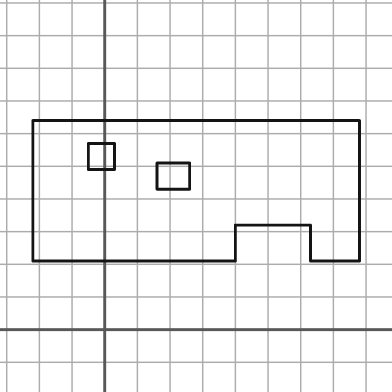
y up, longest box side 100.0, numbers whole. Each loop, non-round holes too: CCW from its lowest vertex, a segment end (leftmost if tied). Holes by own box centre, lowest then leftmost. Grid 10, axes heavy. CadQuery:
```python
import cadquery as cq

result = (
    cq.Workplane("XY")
    .moveTo(-22.0, 21.0)
    .lineTo(40.0, 21.0)
    .lineTo(40.0, 32.0)
    .lineTo(63.0, 32.0)
    .lineTo(63.0, 21.0)
    .lineTo(78.0, 21.0)
    .lineTo(78.0, 64.0)
    .lineTo(-22.0, 64.0)
    .close()
    .moveTo(16.0, 43.0)
    .lineTo(26.0, 43.0)
    .lineTo(26.0, 51.0)
    .lineTo(16.0, 51.0)
    .close()
    .moveTo(-5.0, 49.0)
    .lineTo(3.0, 49.0)
    .lineTo(3.0, 57.0)
    .lineTo(-5.0, 57.0)
    .close()
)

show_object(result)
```